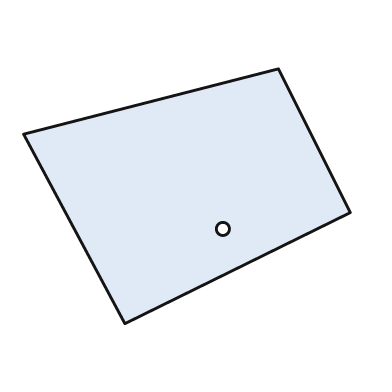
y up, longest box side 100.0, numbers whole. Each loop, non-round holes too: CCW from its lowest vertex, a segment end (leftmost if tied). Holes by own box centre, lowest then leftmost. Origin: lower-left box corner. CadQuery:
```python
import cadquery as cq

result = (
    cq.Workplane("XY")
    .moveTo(31.0, 0.0)
    .lineTo(100.0, 34.0)
    .lineTo(78.0, 78.0)
    .lineTo(0.0, 58.0)
    .close()
    .moveTo(61.0, 29.0)
    .circle(2.0)
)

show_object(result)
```